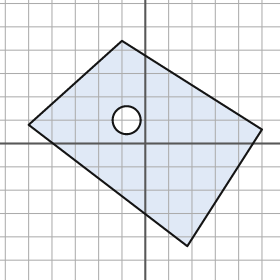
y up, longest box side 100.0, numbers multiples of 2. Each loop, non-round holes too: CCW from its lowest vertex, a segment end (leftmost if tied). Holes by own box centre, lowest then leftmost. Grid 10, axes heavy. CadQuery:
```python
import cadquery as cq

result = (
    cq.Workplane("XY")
    .moveTo(18.0, -44.0)
    .lineTo(50.0, 6.0)
    .lineTo(-10.0, 44.0)
    .lineTo(-50.0, 8.0)
    .close()
    .moveTo(-8.0, 10.0)
    .circle(6.0)
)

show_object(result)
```